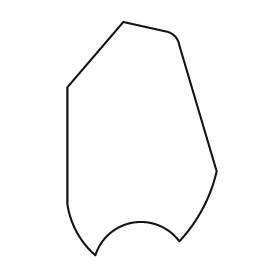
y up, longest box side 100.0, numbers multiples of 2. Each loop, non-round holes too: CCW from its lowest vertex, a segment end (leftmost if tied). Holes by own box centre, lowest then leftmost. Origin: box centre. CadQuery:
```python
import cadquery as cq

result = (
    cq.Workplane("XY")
    .moveTo(-20.0, -50.0)
    .threePointArc((-4.0, -36.0), (16.0, -44.0))
    .threePointArc((26.0, -30.0), (32.0, -14.0))
    .lineTo(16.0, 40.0)
    .threePointArc((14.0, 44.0), (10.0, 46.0))
    .lineTo(-8.0, 50.0)
    .lineTo(-32.0, 22.0)
    .lineTo(-32.0, -28.0)
    .threePointArc((-28.0, -40.0), (-20.0, -50.0))
    .close()
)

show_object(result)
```